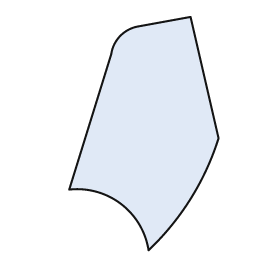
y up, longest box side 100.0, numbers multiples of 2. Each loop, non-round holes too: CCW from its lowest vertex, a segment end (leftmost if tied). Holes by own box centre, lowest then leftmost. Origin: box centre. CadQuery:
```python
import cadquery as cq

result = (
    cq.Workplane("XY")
    .moveTo(2.0, -50.0)
    .threePointArc((20.0, -28.0), (32.0, -2.0))
    .lineTo(20.0, 50.0)
    .lineTo(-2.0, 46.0)
    .threePointArc((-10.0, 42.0), (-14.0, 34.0))
    .lineTo(-32.0, -24.0)
    .threePointArc((-10.0, -30.0), (2.0, -50.0))
    .close()
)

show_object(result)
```